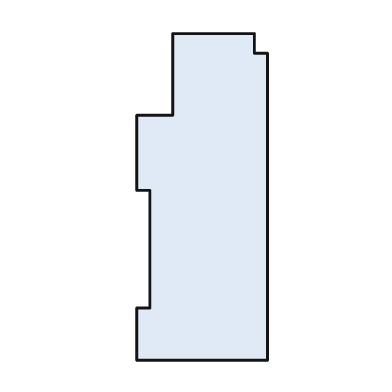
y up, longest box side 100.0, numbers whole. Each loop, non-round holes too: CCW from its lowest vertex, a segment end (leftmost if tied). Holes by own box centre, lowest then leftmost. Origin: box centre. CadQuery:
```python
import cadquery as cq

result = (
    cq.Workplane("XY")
    .moveTo(-20.0, -50.0)
    .lineTo(20.0, -50.0)
    .lineTo(20.0, 44.0)
    .lineTo(16.0, 44.0)
    .lineTo(16.0, 50.0)
    .lineTo(-9.0, 50.0)
    .lineTo(-9.0, 25.0)
    .lineTo(-20.0, 25.0)
    .lineTo(-20.0, 2.0)
    .lineTo(-16.0, 2.0)
    .lineTo(-16.0, -34.0)
    .lineTo(-20.0, -34.0)
    .close()
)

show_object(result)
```